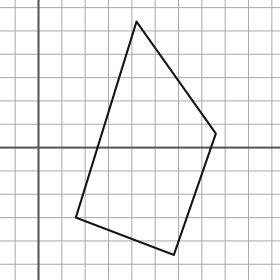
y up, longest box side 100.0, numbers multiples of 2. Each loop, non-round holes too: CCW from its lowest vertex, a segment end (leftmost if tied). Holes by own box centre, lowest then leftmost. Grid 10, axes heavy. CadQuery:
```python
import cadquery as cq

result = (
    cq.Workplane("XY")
    .moveTo(58.0, -46.0)
    .lineTo(76.0, 6.0)
    .lineTo(42.0, 54.0)
    .lineTo(16.0, -30.0)
    .close()
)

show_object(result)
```